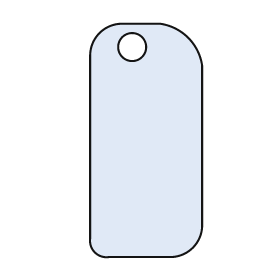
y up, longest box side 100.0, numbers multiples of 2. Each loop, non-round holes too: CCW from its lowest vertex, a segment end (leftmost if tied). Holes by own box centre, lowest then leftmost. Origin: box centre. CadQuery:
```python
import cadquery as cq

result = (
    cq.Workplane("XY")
    .moveTo(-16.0, -50.0)
    .lineTo(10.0, -50.0)
    .threePointArc((20.0, -46.0), (24.0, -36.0))
    .lineTo(24.0, 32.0)
    .threePointArc((18.0, 44.0), (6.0, 50.0))
    .lineTo(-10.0, 50.0)
    .threePointArc((-20.0, 46.0), (-24.0, 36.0))
    .lineTo(-24.0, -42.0)
    .threePointArc((-22.0, -48.0), (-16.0, -50.0))
    .close()
    .moveTo(-6.0, 40.0)
    .circle(6.0)
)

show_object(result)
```